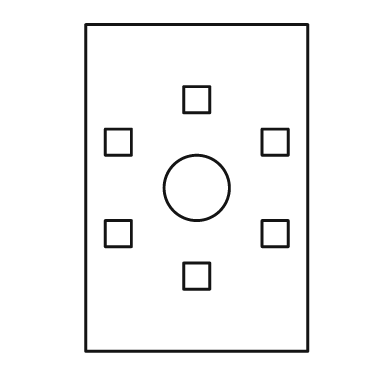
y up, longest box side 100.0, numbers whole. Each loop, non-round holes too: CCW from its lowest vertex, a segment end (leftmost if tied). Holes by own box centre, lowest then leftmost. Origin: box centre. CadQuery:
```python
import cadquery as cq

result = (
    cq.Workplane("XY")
    .moveTo(-34.0, -50.0)
    .lineTo(34.0, -50.0)
    .lineTo(34.0, 50.0)
    .lineTo(-34.0, 50.0)
    .close()
    .moveTo(-4.0, -31.0)
    .lineTo(4.0, -31.0)
    .lineTo(4.0, -23.0)
    .lineTo(-4.0, -23.0)
    .close()
    .moveTo(-28.0, -18.0)
    .lineTo(-20.0, -18.0)
    .lineTo(-20.0, -10.0)
    .lineTo(-28.0, -10.0)
    .close()
    .moveTo(20.0, -18.0)
    .lineTo(28.0, -18.0)
    .lineTo(28.0, -10.0)
    .lineTo(20.0, -10.0)
    .close()
    .moveTo(0.0, 0.0)
    .circle(10.0)
    .moveTo(-28.0, 10.0)
    .lineTo(-20.0, 10.0)
    .lineTo(-20.0, 18.0)
    .lineTo(-28.0, 18.0)
    .close()
    .moveTo(20.0, 10.0)
    .lineTo(28.0, 10.0)
    .lineTo(28.0, 18.0)
    .lineTo(20.0, 18.0)
    .close()
    .moveTo(-4.0, 23.0)
    .lineTo(4.0, 23.0)
    .lineTo(4.0, 31.0)
    .lineTo(-4.0, 31.0)
    .close()
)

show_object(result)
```